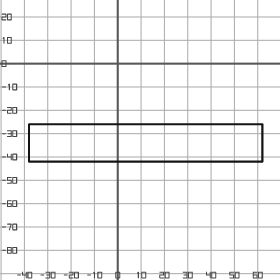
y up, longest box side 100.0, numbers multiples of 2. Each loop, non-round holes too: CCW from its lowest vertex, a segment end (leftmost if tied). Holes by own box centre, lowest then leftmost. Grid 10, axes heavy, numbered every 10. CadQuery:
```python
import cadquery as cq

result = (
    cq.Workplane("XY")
    .moveTo(-38.0, -42.0)
    .lineTo(62.0, -42.0)
    .lineTo(62.0, -26.0)
    .lineTo(-38.0, -26.0)
    .close()
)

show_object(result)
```